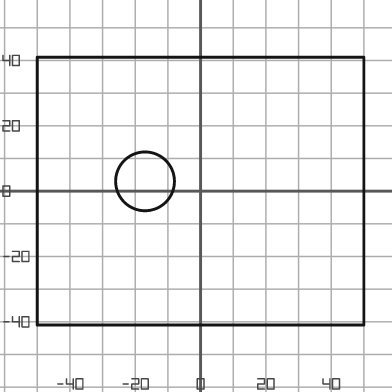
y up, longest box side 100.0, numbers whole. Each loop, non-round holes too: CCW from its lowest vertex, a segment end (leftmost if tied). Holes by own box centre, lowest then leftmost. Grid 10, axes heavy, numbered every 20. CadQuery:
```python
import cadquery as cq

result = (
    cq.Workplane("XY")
    .moveTo(-50.0, -41.0)
    .lineTo(50.0, -41.0)
    .lineTo(50.0, 41.0)
    .lineTo(-50.0, 41.0)
    .close()
    .moveTo(-17.0, 3.0)
    .circle(9.0)
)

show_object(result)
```